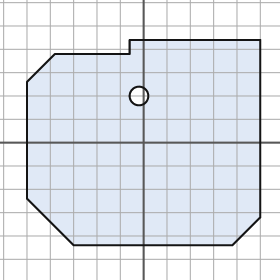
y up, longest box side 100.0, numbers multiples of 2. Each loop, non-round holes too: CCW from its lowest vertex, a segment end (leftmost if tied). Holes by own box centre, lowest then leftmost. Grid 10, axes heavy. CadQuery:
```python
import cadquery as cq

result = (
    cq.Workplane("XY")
    .moveTo(-30.0, -44.0)
    .lineTo(38.0, -44.0)
    .lineTo(50.0, -32.0)
    .lineTo(50.0, 44.0)
    .lineTo(-6.0, 44.0)
    .lineTo(-6.0, 38.0)
    .lineTo(-38.0, 38.0)
    .lineTo(-50.0, 26.0)
    .lineTo(-50.0, -24.0)
    .close()
    .moveTo(-2.0, 20.0)
    .circle(4.0)
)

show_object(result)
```